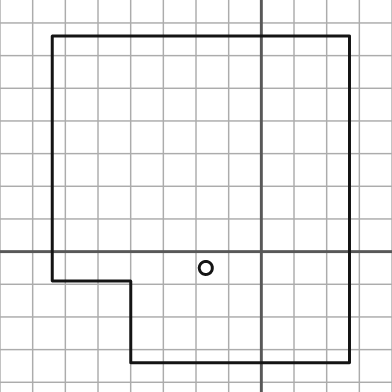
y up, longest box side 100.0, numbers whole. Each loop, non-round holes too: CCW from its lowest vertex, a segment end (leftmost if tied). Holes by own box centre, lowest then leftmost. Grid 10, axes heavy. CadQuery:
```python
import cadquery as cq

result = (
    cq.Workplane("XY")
    .moveTo(-40.0, -34.0)
    .lineTo(27.0, -34.0)
    .lineTo(27.0, 66.0)
    .lineTo(-64.0, 66.0)
    .lineTo(-64.0, -9.0)
    .lineTo(-40.0, -9.0)
    .close()
    .moveTo(-17.0, -5.0)
    .circle(2.0)
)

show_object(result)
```